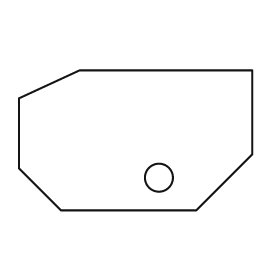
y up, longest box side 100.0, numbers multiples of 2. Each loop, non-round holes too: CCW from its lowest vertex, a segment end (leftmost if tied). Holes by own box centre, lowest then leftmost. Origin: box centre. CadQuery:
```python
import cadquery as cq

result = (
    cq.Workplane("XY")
    .moveTo(-32.0, -30.0)
    .lineTo(26.0, -30.0)
    .lineTo(50.0, -6.0)
    .lineTo(50.0, 30.0)
    .lineTo(-24.0, 30.0)
    .lineTo(-50.0, 18.0)
    .lineTo(-50.0, -12.0)
    .close()
    .moveTo(10.0, -16.0)
    .circle(6.0)
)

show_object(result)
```